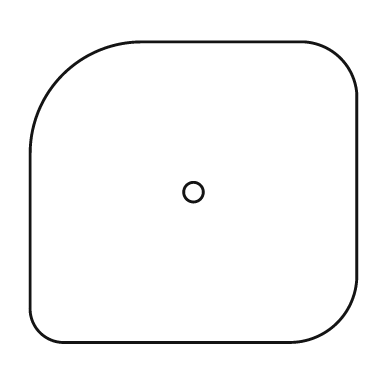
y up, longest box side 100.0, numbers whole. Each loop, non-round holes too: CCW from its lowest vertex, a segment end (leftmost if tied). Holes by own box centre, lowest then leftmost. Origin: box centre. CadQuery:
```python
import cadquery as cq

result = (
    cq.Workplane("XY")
    .moveTo(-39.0, -46.0)
    .lineTo(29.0, -46.0)
    .threePointArc((44.0, -40.0), (50.0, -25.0))
    .lineTo(50.0, 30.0)
    .threePointArc((45.0, 41.0), (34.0, 46.0))
    .lineTo(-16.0, 46.0)
    .threePointArc((-40.0, 36.0), (-50.0, 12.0))
    .lineTo(-50.0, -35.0)
    .threePointArc((-47.0, -43.0), (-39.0, -46.0))
    .close()
    .moveTo(0.0, 0.0)
    .circle(3.0)
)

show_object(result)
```